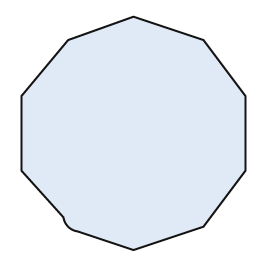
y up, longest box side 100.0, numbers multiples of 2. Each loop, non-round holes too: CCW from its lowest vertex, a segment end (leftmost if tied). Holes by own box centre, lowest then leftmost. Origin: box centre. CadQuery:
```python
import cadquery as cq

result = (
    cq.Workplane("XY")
    .moveTo(0.0, -50.0)
    .lineTo(30.0, -40.0)
    .lineTo(48.0, -16.0)
    .lineTo(48.0, 16.0)
    .lineTo(30.0, 40.0)
    .lineTo(0.0, 50.0)
    .lineTo(-28.0, 40.0)
    .lineTo(-48.0, 16.0)
    .lineTo(-48.0, -16.0)
    .lineTo(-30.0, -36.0)
    .threePointArc((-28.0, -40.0), (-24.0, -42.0))
    .close()
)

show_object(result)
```